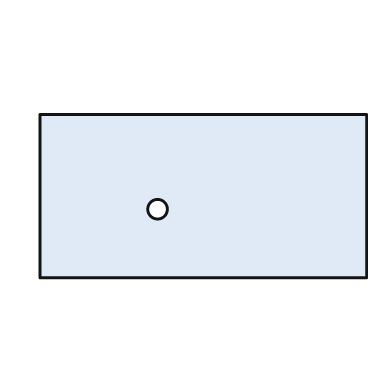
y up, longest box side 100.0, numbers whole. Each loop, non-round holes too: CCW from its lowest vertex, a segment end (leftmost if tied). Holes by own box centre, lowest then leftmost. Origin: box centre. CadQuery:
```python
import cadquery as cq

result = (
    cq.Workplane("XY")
    .moveTo(-50.0, -25.0)
    .lineTo(50.0, -25.0)
    .lineTo(50.0, 25.0)
    .lineTo(-50.0, 25.0)
    .close()
    .moveTo(-14.0, -4.0)
    .circle(3.0)
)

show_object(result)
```